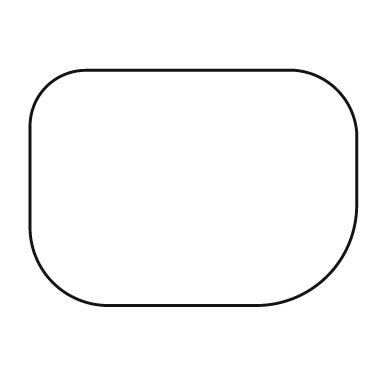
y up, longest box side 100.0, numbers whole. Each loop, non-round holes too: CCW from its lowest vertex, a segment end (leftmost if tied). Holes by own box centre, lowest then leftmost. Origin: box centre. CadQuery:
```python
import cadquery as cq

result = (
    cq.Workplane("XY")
    .moveTo(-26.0, -36.0)
    .lineTo(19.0, -36.0)
    .threePointArc((41.0, -27.0), (50.0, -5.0))
    .lineTo(50.0, 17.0)
    .threePointArc((44.0, 30.0), (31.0, 36.0))
    .lineTo(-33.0, 36.0)
    .threePointArc((-45.0, 31.0), (-50.0, 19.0))
    .lineTo(-50.0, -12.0)
    .threePointArc((-43.0, -29.0), (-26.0, -36.0))
    .close()
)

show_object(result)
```